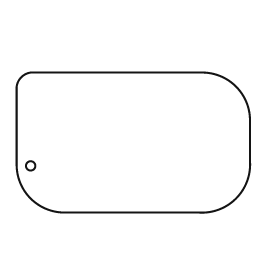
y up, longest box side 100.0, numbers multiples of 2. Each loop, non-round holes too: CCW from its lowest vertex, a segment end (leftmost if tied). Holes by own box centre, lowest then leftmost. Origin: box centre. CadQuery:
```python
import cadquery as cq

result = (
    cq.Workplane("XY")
    .moveTo(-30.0, -30.0)
    .lineTo(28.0, -30.0)
    .threePointArc((44.0, -24.0), (50.0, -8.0))
    .lineTo(50.0, 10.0)
    .threePointArc((44.0, 24.0), (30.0, 30.0))
    .lineTo(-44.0, 30.0)
    .threePointArc((-48.0, 28.0), (-50.0, 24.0))
    .lineTo(-50.0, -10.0)
    .threePointArc((-44.0, -24.0), (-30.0, -30.0))
    .close()
    .moveTo(-44.0, -10.0)
    .circle(2.0)
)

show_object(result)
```